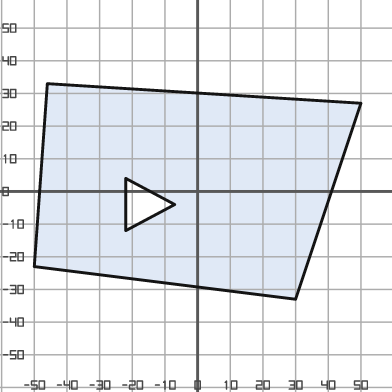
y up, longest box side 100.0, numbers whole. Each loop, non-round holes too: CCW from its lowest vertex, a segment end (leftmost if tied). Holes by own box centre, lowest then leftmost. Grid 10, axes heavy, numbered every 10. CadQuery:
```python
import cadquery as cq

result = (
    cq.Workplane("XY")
    .moveTo(30.0, -33.0)
    .lineTo(50.0, 27.0)
    .lineTo(-46.0, 33.0)
    .lineTo(-50.0, -23.0)
    .close()
    .moveTo(-22.0, -12.0)
    .lineTo(-7.0, -4.0)
    .lineTo(-22.0, 4.0)
    .close()
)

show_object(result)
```